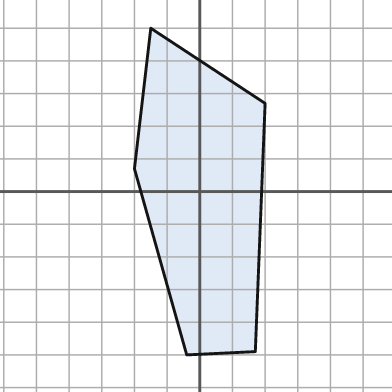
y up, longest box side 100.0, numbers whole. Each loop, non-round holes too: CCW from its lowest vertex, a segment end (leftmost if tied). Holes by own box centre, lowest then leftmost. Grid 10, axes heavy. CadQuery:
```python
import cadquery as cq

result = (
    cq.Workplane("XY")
    .moveTo(-4.0, -50.0)
    .lineTo(17.0, -49.0)
    .lineTo(20.0, 27.0)
    .lineTo(-15.0, 50.0)
    .lineTo(-20.0, 7.0)
    .close()
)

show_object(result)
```